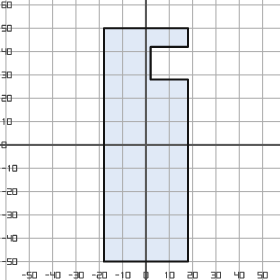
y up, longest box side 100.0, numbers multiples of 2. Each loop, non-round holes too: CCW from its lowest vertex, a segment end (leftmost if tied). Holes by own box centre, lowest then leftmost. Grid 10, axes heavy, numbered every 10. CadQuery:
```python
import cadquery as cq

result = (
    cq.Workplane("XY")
    .moveTo(-18.0, -50.0)
    .lineTo(18.0, -50.0)
    .lineTo(18.0, 28.0)
    .lineTo(2.0, 28.0)
    .lineTo(2.0, 42.0)
    .lineTo(18.0, 42.0)
    .lineTo(18.0, 50.0)
    .lineTo(-18.0, 50.0)
    .close()
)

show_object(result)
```